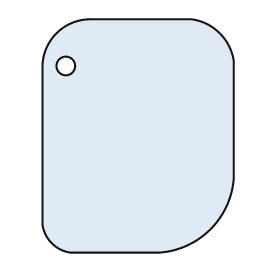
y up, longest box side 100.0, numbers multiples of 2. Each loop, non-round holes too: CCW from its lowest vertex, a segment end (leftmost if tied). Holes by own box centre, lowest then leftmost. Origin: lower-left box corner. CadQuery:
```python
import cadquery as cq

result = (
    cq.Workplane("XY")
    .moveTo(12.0, 0.0)
    .lineTo(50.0, 0.0)
    .threePointArc((72.0, 10.0), (82.0, 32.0))
    .lineTo(82.0, 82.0)
    .threePointArc((76.0, 94.0), (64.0, 100.0))
    .lineTo(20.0, 100.0)
    .threePointArc((6.0, 94.0), (0.0, 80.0))
    .lineTo(0.0, 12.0)
    .threePointArc((4.0, 4.0), (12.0, 0.0))
    .close()
    .moveTo(10.0, 80.0)
    .circle(4.0)
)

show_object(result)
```